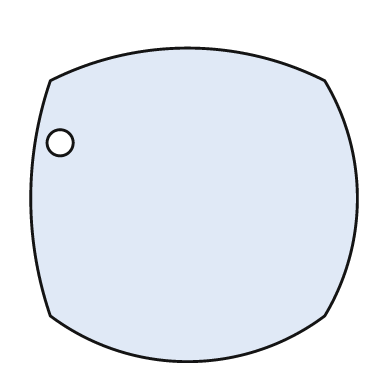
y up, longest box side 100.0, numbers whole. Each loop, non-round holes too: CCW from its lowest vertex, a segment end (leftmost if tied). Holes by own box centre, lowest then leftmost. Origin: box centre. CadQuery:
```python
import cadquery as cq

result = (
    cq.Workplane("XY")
    .moveTo(-44.0, -34.0)
    .threePointArc((-2.0, -48.0), (40.0, -34.0))
    .threePointArc((50.0, 2.0), (40.0, 38.0))
    .threePointArc((-2.0, 48.0), (-44.0, 38.0))
    .threePointArc((-50.0, 2.0), (-44.0, -34.0))
    .close()
    .moveTo(-41.0, 19.0)
    .circle(4.0)
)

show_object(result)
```